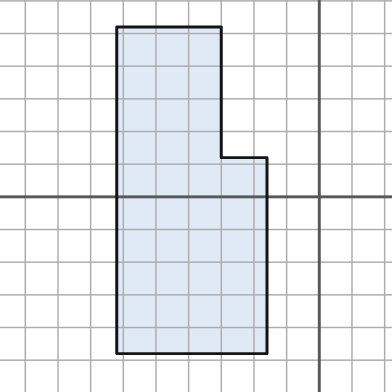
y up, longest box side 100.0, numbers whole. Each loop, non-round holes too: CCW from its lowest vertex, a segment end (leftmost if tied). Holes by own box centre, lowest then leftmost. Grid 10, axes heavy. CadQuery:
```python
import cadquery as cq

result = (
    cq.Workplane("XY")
    .moveTo(-62.0, -48.0)
    .lineTo(-16.0, -48.0)
    .lineTo(-16.0, 12.0)
    .lineTo(-30.0, 12.0)
    .lineTo(-30.0, 52.0)
    .lineTo(-62.0, 52.0)
    .close()
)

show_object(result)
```